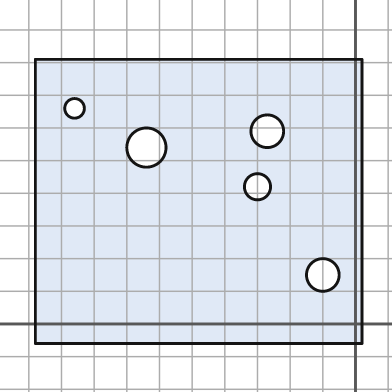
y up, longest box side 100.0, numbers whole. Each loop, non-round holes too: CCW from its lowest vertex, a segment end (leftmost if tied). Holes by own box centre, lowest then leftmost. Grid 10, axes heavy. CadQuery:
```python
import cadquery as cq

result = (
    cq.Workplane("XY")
    .moveTo(-98.0, -6.0)
    .lineTo(2.0, -6.0)
    .lineTo(2.0, 81.0)
    .lineTo(-98.0, 81.0)
    .close()
    .moveTo(-10.0, 15.0)
    .circle(5.0)
    .moveTo(-30.0, 42.0)
    .circle(4.0)
    .moveTo(-64.0, 54.0)
    .circle(6.0)
    .moveTo(-27.0, 59.0)
    .circle(5.0)
    .moveTo(-86.0, 66.0)
    .circle(3.0)
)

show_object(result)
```